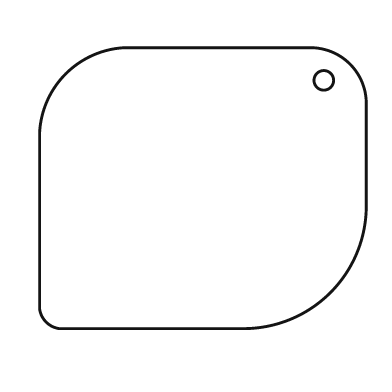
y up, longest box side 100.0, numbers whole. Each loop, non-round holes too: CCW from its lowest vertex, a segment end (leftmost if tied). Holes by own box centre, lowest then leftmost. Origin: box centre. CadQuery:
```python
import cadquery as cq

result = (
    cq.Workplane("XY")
    .moveTo(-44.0, -43.0)
    .lineTo(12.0, -43.0)
    .threePointArc((39.0, -32.0), (50.0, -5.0))
    .lineTo(50.0, 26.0)
    .threePointArc((45.0, 38.0), (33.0, 43.0))
    .lineTo(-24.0, 43.0)
    .threePointArc((-42.0, 35.0), (-50.0, 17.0))
    .lineTo(-50.0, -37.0)
    .threePointArc((-48.0, -41.0), (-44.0, -43.0))
    .close()
    .moveTo(37.0, 33.0)
    .circle(3.0)
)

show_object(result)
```